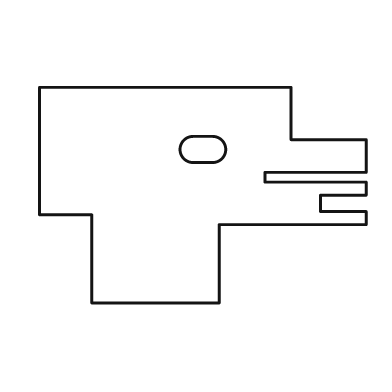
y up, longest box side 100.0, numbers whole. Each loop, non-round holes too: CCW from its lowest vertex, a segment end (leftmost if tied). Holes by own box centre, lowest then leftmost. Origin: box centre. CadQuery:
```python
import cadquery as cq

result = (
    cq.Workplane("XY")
    .moveTo(-34.0, -33.0)
    .lineTo(5.0, -33.0)
    .lineTo(5.0, -9.0)
    .lineTo(50.0, -9.0)
    .lineTo(50.0, -5.0)
    .lineTo(36.0, -5.0)
    .lineTo(36.0, 0.0)
    .lineTo(50.0, 0.0)
    .lineTo(50.0, 4.0)
    .lineTo(19.0, 4.0)
    .lineTo(19.0, 7.0)
    .lineTo(50.0, 7.0)
    .lineTo(50.0, 17.0)
    .lineTo(27.0, 17.0)
    .lineTo(27.0, 33.0)
    .lineTo(-50.0, 33.0)
    .lineTo(-50.0, -6.0)
    .lineTo(-34.0, -6.0)
    .close()
    .moveTo(-3.0, 10.0)
    .lineTo(3.0, 10.0)
    .threePointArc((7.0, 14.0), (3.0, 18.0))
    .lineTo(-3.0, 18.0)
    .threePointArc((-7.0, 14.0), (-3.0, 10.0))
    .close()
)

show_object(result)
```